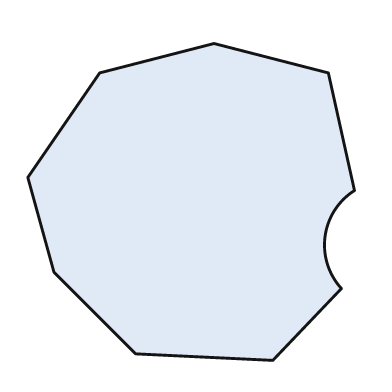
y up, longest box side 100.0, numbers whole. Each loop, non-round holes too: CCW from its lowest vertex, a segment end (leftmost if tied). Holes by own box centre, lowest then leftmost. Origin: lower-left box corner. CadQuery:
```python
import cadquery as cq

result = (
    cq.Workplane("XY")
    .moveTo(75.0, 0.0)
    .lineTo(96.0, 22.0)
    .threePointArc((91.0, 38.0), (100.0, 52.0))
    .lineTo(92.0, 88.0)
    .lineTo(57.0, 97.0)
    .lineTo(22.0, 88.0)
    .lineTo(0.0, 56.0)
    .lineTo(8.0, 27.0)
    .lineTo(33.0, 2.0)
    .close()
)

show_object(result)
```